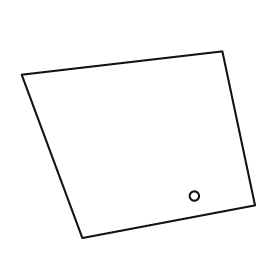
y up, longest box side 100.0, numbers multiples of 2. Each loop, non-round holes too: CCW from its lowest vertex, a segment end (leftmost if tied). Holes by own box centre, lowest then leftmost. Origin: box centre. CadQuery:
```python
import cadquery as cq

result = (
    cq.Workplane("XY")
    .moveTo(-24.0, -40.0)
    .lineTo(50.0, -26.0)
    .lineTo(36.0, 40.0)
    .lineTo(-50.0, 30.0)
    .close()
    .moveTo(24.0, -22.0)
    .circle(2.0)
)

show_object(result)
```